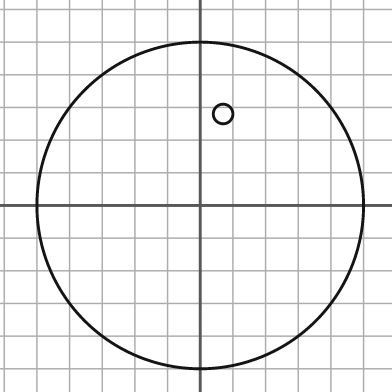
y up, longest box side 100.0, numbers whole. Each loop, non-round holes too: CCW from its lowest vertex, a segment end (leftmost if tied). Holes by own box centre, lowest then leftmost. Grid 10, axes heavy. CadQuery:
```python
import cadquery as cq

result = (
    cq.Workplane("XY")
    .moveTo(0.0, 0.0)
    .circle(50.0)
    .moveTo(7.0, 28.0)
    .circle(3.0)
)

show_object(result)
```